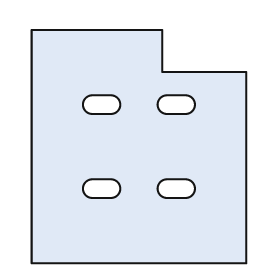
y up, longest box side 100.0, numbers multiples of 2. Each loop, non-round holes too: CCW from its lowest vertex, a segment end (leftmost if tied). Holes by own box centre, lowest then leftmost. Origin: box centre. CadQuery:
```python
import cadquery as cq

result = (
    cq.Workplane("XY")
    .moveTo(-46.0, -50.0)
    .lineTo(46.0, -50.0)
    .lineTo(46.0, 32.0)
    .lineTo(10.0, 32.0)
    .lineTo(10.0, 50.0)
    .lineTo(-46.0, 50.0)
    .close()
    .moveTo(-20.0, -22.0)
    .lineTo(-12.0, -22.0)
    .threePointArc((-8.0, -18.0), (-12.0, -14.0))
    .lineTo(-20.0, -14.0)
    .threePointArc((-24.0, -18.0), (-20.0, -22.0))
    .close()
    .moveTo(12.0, -22.0)
    .lineTo(20.0, -22.0)
    .threePointArc((24.0, -18.0), (20.0, -14.0))
    .lineTo(12.0, -14.0)
    .threePointArc((8.0, -18.0), (12.0, -22.0))
    .close()
    .moveTo(-20.0, 14.0)
    .lineTo(-12.0, 14.0)
    .threePointArc((-8.0, 18.0), (-12.0, 22.0))
    .lineTo(-20.0, 22.0)
    .threePointArc((-24.0, 18.0), (-20.0, 14.0))
    .close()
    .moveTo(12.0, 14.0)
    .lineTo(20.0, 14.0)
    .threePointArc((24.0, 18.0), (20.0, 22.0))
    .lineTo(12.0, 22.0)
    .threePointArc((8.0, 18.0), (12.0, 14.0))
    .close()
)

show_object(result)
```